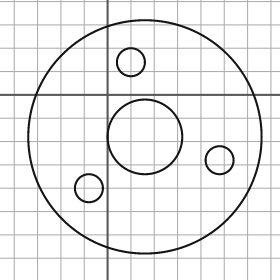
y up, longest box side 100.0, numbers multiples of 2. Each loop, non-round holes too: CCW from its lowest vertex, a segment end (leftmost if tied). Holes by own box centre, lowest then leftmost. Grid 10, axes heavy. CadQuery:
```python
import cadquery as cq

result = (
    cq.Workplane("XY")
    .moveTo(16.0, -18.0)
    .circle(50.0)
    .moveTo(-8.0, -40.0)
    .circle(6.0)
    .moveTo(48.0, -28.0)
    .circle(6.0)
    .moveTo(16.0, -18.0)
    .circle(16.0)
    .moveTo(10.0, 14.0)
    .circle(6.0)
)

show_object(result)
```